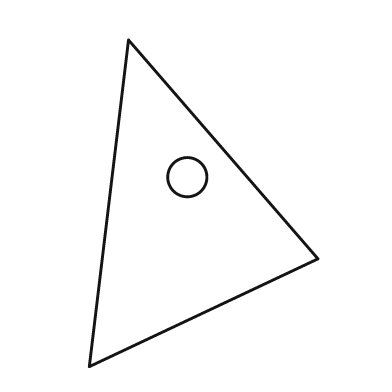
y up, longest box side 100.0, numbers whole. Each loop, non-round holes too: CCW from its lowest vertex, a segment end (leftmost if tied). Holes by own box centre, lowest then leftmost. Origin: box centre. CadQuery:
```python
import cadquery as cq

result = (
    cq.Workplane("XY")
    .moveTo(-35.0, -50.0)
    .lineTo(35.0, -17.0)
    .lineTo(-23.0, 50.0)
    .close()
    .moveTo(-5.0, 8.0)
    .circle(6.0)
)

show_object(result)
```